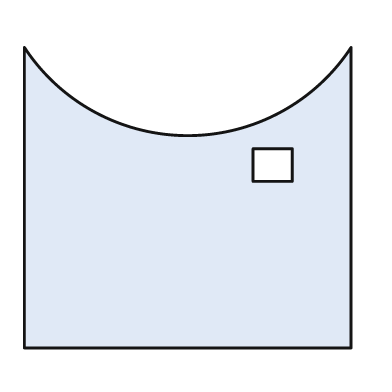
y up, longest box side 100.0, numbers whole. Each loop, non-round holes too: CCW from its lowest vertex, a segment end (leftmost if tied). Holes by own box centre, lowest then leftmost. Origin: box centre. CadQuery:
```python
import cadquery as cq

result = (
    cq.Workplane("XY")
    .moveTo(-50.0, -46.0)
    .lineTo(50.0, -46.0)
    .lineTo(50.0, 46.0)
    .threePointArc((0.0, 19.0), (-50.0, 46.0))
    .close()
    .moveTo(20.0, 5.0)
    .lineTo(32.0, 5.0)
    .lineTo(32.0, 15.0)
    .lineTo(20.0, 15.0)
    .close()
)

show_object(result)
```